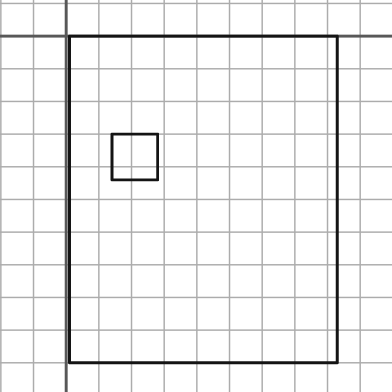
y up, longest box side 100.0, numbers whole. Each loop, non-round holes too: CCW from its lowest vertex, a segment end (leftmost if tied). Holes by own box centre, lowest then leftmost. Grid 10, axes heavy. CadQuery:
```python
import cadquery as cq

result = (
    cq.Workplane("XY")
    .moveTo(1.0, -100.0)
    .lineTo(83.0, -100.0)
    .lineTo(83.0, 0.0)
    .lineTo(1.0, 0.0)
    .close()
    .moveTo(14.0, -44.0)
    .lineTo(28.0, -44.0)
    .lineTo(28.0, -30.0)
    .lineTo(14.0, -30.0)
    .close()
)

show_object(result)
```